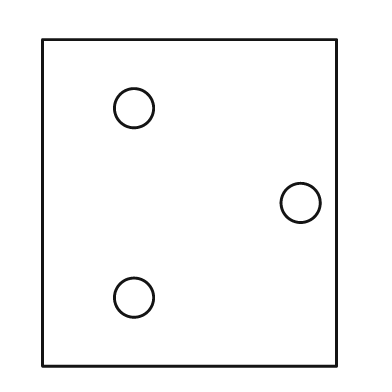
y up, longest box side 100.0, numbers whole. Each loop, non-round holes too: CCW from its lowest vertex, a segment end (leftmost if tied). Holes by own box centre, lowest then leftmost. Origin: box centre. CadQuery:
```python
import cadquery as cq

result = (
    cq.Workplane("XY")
    .moveTo(-45.0, -50.0)
    .lineTo(45.0, -50.0)
    .lineTo(45.0, 50.0)
    .lineTo(-45.0, 50.0)
    .close()
    .moveTo(-17.0, -29.0)
    .circle(6.0)
    .moveTo(34.0, 0.0)
    .circle(6.0)
    .moveTo(-17.0, 29.0)
    .circle(6.0)
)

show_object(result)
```